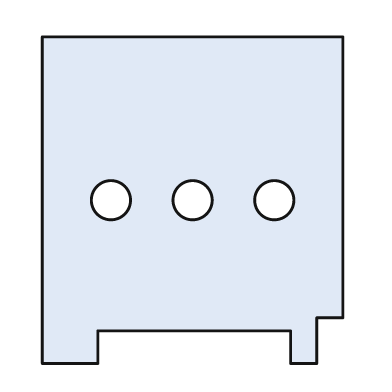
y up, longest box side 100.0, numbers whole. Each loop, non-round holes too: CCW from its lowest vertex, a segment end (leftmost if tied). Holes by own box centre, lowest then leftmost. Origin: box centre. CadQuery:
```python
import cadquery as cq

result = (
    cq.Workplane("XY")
    .moveTo(-46.0, -50.0)
    .lineTo(-29.0, -50.0)
    .lineTo(-29.0, -40.0)
    .lineTo(30.0, -40.0)
    .lineTo(30.0, -50.0)
    .lineTo(38.0, -50.0)
    .lineTo(38.0, -36.0)
    .lineTo(46.0, -36.0)
    .lineTo(46.0, 50.0)
    .lineTo(-46.0, 50.0)
    .close()
    .moveTo(-25.0, 0.0)
    .circle(6.0)
    .moveTo(0.0, 0.0)
    .circle(6.0)
    .moveTo(25.0, 0.0)
    .circle(6.0)
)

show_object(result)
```